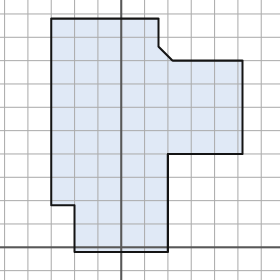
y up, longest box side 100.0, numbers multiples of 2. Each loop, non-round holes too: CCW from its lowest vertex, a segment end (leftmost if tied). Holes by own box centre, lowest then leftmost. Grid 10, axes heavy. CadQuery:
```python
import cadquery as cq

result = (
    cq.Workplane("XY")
    .moveTo(-20.0, -2.0)
    .lineTo(20.0, -2.0)
    .lineTo(20.0, 40.0)
    .lineTo(52.0, 40.0)
    .lineTo(52.0, 80.0)
    .lineTo(22.0, 80.0)
    .lineTo(16.0, 86.0)
    .lineTo(16.0, 98.0)
    .lineTo(-30.0, 98.0)
    .lineTo(-30.0, 18.0)
    .lineTo(-20.0, 18.0)
    .close()
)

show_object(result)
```